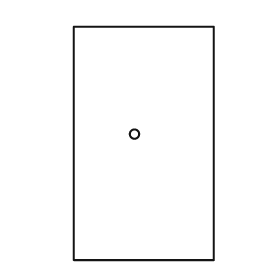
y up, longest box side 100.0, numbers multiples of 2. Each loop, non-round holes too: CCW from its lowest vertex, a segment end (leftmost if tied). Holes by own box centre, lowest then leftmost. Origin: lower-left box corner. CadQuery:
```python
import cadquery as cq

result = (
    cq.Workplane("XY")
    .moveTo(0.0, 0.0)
    .lineTo(60.0, 0.0)
    .lineTo(60.0, 100.0)
    .lineTo(0.0, 100.0)
    .close()
    .moveTo(26.0, 54.0)
    .circle(2.0)
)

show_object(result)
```